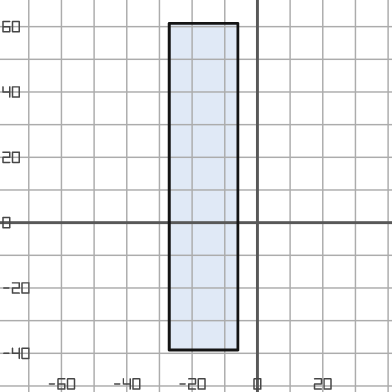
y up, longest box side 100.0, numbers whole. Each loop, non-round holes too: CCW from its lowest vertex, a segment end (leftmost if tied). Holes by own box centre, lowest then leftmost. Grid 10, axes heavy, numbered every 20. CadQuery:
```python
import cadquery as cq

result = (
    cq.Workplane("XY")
    .moveTo(-27.0, -39.0)
    .lineTo(-6.0, -39.0)
    .lineTo(-6.0, 61.0)
    .lineTo(-27.0, 61.0)
    .close()
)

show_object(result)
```